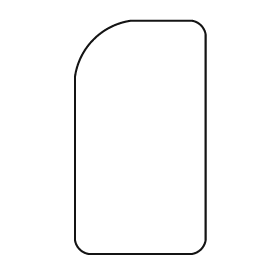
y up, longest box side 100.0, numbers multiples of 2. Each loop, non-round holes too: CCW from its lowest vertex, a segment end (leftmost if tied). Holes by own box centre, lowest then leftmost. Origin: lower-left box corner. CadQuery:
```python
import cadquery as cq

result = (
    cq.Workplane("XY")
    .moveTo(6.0, 0.0)
    .lineTo(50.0, 0.0)
    .threePointArc((54.0, 2.0), (56.0, 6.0))
    .lineTo(56.0, 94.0)
    .threePointArc((54.0, 98.0), (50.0, 100.0))
    .lineTo(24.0, 100.0)
    .threePointArc((8.0, 92.0), (0.0, 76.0))
    .lineTo(0.0, 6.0)
    .threePointArc((2.0, 2.0), (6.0, 0.0))
    .close()
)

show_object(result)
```